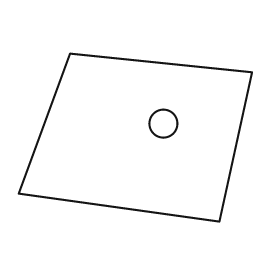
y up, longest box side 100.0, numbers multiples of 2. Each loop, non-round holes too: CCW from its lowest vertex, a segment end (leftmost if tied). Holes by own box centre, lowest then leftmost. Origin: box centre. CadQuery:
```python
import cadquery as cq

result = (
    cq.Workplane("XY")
    .moveTo(36.0, -36.0)
    .lineTo(50.0, 28.0)
    .lineTo(-28.0, 36.0)
    .lineTo(-50.0, -24.0)
    .close()
    .moveTo(12.0, 6.0)
    .circle(6.0)
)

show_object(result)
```